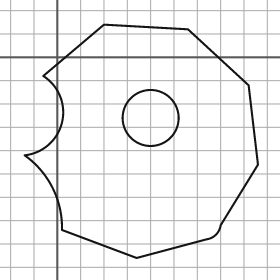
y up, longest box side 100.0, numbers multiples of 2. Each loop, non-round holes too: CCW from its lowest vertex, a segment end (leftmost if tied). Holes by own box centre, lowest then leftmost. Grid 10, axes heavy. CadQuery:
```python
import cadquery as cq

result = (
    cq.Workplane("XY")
    .moveTo(34.0, -86.0)
    .lineTo(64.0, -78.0)
    .threePointArc((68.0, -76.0), (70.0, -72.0))
    .lineTo(86.0, -46.0)
    .lineTo(82.0, -12.0)
    .lineTo(56.0, 12.0)
    .lineTo(20.0, 14.0)
    .lineTo(-6.0, -8.0)
    .threePointArc((2.0, -28.0), (-14.0, -42.0))
    .threePointArc((-2.0, -56.0), (2.0, -74.0))
    .close()
    .moveTo(40.0, -26.0)
    .circle(12.0)
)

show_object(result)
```